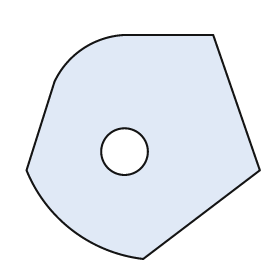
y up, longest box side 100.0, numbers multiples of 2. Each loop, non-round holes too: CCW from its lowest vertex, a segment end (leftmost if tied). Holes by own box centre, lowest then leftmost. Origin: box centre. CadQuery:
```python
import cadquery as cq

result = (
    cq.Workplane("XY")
    .moveTo(0.0, -48.0)
    .lineTo(50.0, -10.0)
    .lineTo(30.0, 48.0)
    .lineTo(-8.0, 48.0)
    .threePointArc((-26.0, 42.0), (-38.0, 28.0))
    .lineTo(-50.0, -10.0)
    .threePointArc((-30.0, -36.0), (0.0, -48.0))
    .close()
    .moveTo(-8.0, -2.0)
    .circle(10.0)
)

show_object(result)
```